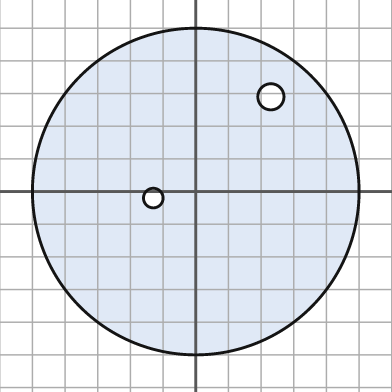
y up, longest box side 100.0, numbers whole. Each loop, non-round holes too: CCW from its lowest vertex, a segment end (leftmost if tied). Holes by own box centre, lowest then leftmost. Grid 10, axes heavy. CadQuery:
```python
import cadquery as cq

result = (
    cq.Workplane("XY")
    .moveTo(0.0, 0.0)
    .circle(50.0)
    .moveTo(-13.0, -2.0)
    .circle(3.0)
    .moveTo(23.0, 29.0)
    .circle(4.0)
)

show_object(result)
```